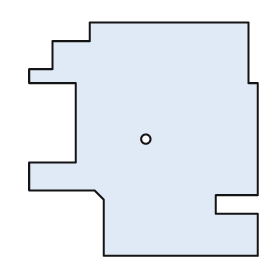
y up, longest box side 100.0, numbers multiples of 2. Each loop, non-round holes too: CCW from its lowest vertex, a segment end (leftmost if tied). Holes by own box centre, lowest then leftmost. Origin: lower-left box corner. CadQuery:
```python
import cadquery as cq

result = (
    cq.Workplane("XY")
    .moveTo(32.0, 0.0)
    .lineTo(98.0, 0.0)
    .lineTo(98.0, 18.0)
    .lineTo(80.0, 18.0)
    .lineTo(80.0, 26.0)
    .lineTo(98.0, 26.0)
    .lineTo(98.0, 74.0)
    .lineTo(94.0, 74.0)
    .lineTo(94.0, 100.0)
    .lineTo(26.0, 100.0)
    .lineTo(26.0, 92.0)
    .lineTo(10.0, 92.0)
    .lineTo(10.0, 80.0)
    .lineTo(0.0, 80.0)
    .lineTo(0.0, 74.0)
    .lineTo(20.0, 74.0)
    .lineTo(20.0, 40.0)
    .lineTo(0.0, 40.0)
    .lineTo(0.0, 28.0)
    .lineTo(28.0, 28.0)
    .lineTo(32.0, 24.0)
    .close()
    .moveTo(50.0, 50.0)
    .circle(2.0)
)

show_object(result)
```